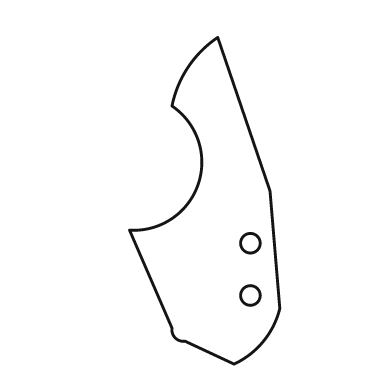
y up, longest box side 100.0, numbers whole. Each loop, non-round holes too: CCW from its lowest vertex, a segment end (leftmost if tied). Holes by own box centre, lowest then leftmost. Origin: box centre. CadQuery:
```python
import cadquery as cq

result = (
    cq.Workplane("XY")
    .moveTo(9.0, -50.0)
    .threePointArc((18.0, -43.0), (23.0, -33.0))
    .lineTo(20.0, 3.0)
    .lineTo(4.0, 50.0)
    .threePointArc((-5.0, 41.0), (-10.0, 29.0))
    .threePointArc((-2.0, 5.0), (-23.0, -9.0))
    .lineTo(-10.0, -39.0)
    .threePointArc((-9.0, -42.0), (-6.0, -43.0))
    .close()
    .moveTo(14.0, -29.0)
    .circle(3.0)
    .moveTo(14.0, -13.0)
    .circle(3.0)
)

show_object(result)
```